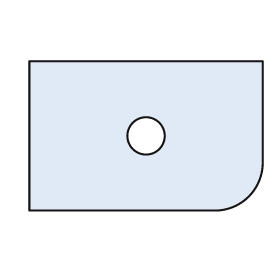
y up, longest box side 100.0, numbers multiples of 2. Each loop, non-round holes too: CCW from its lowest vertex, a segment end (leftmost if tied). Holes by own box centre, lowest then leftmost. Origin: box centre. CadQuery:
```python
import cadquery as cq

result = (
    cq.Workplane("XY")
    .moveTo(-50.0, -32.0)
    .lineTo(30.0, -32.0)
    .threePointArc((44.0, -26.0), (50.0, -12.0))
    .lineTo(50.0, 32.0)
    .lineTo(-50.0, 32.0)
    .close()
    .moveTo(0.0, 0.0)
    .circle(8.0)
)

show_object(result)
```